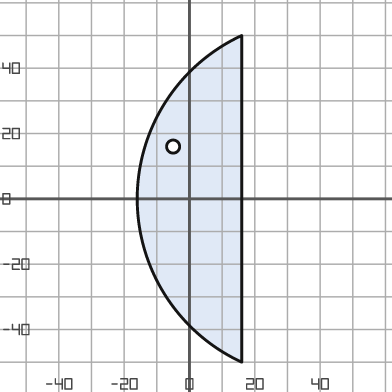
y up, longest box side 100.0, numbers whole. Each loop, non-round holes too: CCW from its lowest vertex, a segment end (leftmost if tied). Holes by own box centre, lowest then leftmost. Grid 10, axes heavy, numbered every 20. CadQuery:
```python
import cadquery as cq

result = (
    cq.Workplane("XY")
    .moveTo(16.0, -50.0)
    .lineTo(16.0, 50.0)
    .threePointArc((-16.0, 0.0), (16.0, -50.0))
    .close()
    .moveTo(-5.0, 16.0)
    .circle(2.0)
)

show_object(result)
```